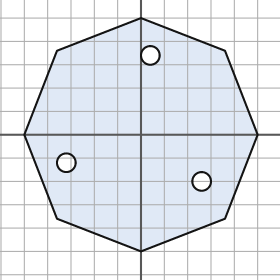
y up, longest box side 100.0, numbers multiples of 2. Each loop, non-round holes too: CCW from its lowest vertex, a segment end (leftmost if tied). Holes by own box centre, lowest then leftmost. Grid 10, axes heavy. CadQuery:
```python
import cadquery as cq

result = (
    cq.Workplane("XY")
    .moveTo(0.0, -50.0)
    .lineTo(36.0, -36.0)
    .lineTo(50.0, 0.0)
    .lineTo(36.0, 36.0)
    .lineTo(0.0, 50.0)
    .lineTo(-36.0, 36.0)
    .lineTo(-50.0, 0.0)
    .lineTo(-36.0, -36.0)
    .close()
    .moveTo(26.0, -20.0)
    .circle(4.0)
    .moveTo(-32.0, -12.0)
    .circle(4.0)
    .moveTo(4.0, 34.0)
    .circle(4.0)
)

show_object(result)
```